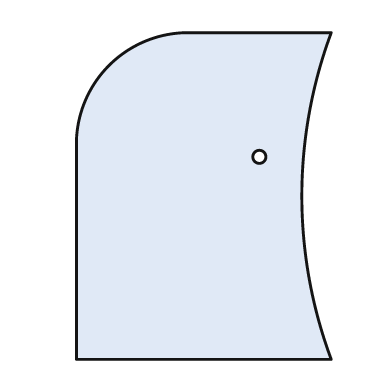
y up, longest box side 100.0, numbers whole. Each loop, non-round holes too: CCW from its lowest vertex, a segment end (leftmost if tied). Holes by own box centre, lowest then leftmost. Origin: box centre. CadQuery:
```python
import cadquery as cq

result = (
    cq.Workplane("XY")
    .moveTo(-39.0, -50.0)
    .lineTo(39.0, -50.0)
    .threePointArc((30.0, 0.0), (39.0, 50.0))
    .lineTo(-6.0, 50.0)
    .threePointArc((-29.0, 40.0), (-39.0, 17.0))
    .close()
    .moveTo(17.0, 12.0)
    .circle(2.0)
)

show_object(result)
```